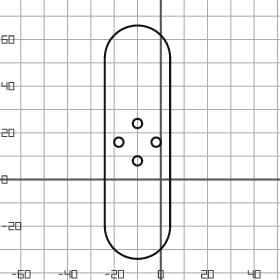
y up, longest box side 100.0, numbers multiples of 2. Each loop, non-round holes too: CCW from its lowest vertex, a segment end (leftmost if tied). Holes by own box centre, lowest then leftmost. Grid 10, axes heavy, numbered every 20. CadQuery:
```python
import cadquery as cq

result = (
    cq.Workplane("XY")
    .moveTo(-24.0, -20.0)
    .threePointArc((-10.0, -34.0), (4.0, -20.0))
    .lineTo(4.0, 52.0)
    .threePointArc((-10.0, 66.0), (-24.0, 52.0))
    .close()
    .moveTo(-10.0, 8.0)
    .circle(2.0)
    .moveTo(-18.0, 16.0)
    .circle(2.0)
    .moveTo(-2.0, 16.0)
    .circle(2.0)
    .moveTo(-10.0, 24.0)
    .circle(2.0)
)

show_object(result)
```